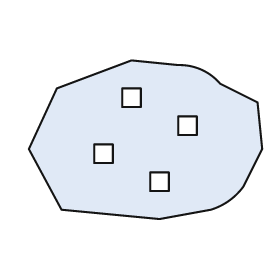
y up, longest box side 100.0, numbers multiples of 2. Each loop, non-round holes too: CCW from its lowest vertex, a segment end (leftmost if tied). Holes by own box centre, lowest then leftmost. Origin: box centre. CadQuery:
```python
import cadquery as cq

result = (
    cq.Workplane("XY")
    .moveTo(6.0, -34.0)
    .lineTo(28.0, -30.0)
    .threePointArc((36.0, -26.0), (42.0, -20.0))
    .lineTo(50.0, -4.0)
    .lineTo(48.0, 16.0)
    .lineTo(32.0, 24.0)
    .threePointArc((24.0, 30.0), (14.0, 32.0))
    .lineTo(-6.0, 34.0)
    .lineTo(-38.0, 22.0)
    .lineTo(-50.0, -4.0)
    .lineTo(-36.0, -30.0)
    .close()
    .moveTo(2.0, -22.0)
    .lineTo(10.0, -22.0)
    .lineTo(10.0, -14.0)
    .lineTo(2.0, -14.0)
    .close()
    .moveTo(-22.0, -10.0)
    .lineTo(-14.0, -10.0)
    .lineTo(-14.0, -2.0)
    .lineTo(-22.0, -2.0)
    .close()
    .moveTo(14.0, 2.0)
    .lineTo(22.0, 2.0)
    .lineTo(22.0, 10.0)
    .lineTo(14.0, 10.0)
    .close()
    .moveTo(-10.0, 14.0)
    .lineTo(-2.0, 14.0)
    .lineTo(-2.0, 22.0)
    .lineTo(-10.0, 22.0)
    .close()
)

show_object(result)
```